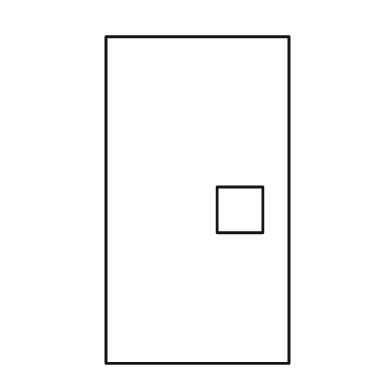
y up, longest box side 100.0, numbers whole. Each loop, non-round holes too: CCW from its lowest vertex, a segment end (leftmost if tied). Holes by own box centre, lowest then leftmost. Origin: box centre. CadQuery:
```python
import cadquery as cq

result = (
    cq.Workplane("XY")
    .moveTo(-28.0, -50.0)
    .lineTo(28.0, -50.0)
    .lineTo(28.0, 50.0)
    .lineTo(-28.0, 50.0)
    .close()
    .moveTo(6.0, -10.0)
    .lineTo(20.0, -10.0)
    .lineTo(20.0, 4.0)
    .lineTo(6.0, 4.0)
    .close()
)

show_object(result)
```